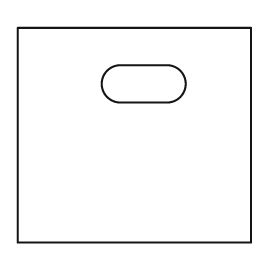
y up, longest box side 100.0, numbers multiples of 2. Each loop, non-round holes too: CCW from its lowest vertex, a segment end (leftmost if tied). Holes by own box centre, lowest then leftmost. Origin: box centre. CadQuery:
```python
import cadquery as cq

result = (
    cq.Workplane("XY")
    .moveTo(-50.0, -46.0)
    .lineTo(50.0, -46.0)
    .lineTo(50.0, 46.0)
    .lineTo(-50.0, 46.0)
    .close()
    .moveTo(-6.0, 14.0)
    .lineTo(14.0, 14.0)
    .threePointArc((22.0, 22.0), (14.0, 30.0))
    .lineTo(-6.0, 30.0)
    .threePointArc((-14.0, 22.0), (-6.0, 14.0))
    .close()
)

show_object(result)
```